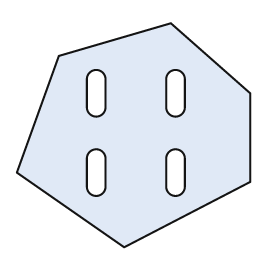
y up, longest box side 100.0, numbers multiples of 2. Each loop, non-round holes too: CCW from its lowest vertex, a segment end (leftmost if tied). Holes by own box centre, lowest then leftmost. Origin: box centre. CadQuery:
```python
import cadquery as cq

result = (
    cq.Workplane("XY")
    .moveTo(-4.0, -48.0)
    .lineTo(50.0, -20.0)
    .lineTo(50.0, 18.0)
    .lineTo(16.0, 48.0)
    .lineTo(-32.0, 34.0)
    .lineTo(-50.0, -16.0)
    .close()
    .moveTo(-20.0, -22.0)
    .threePointArc((-16.0, -26.0), (-12.0, -22.0))
    .lineTo(-12.0, -10.0)
    .threePointArc((-16.0, -6.0), (-20.0, -10.0))
    .close()
    .moveTo(14.0, -22.0)
    .threePointArc((18.0, -26.0), (22.0, -22.0))
    .lineTo(22.0, -10.0)
    .threePointArc((18.0, -6.0), (14.0, -10.0))
    .close()
    .moveTo(-20.0, 12.0)
    .threePointArc((-16.0, 8.0), (-12.0, 12.0))
    .lineTo(-12.0, 24.0)
    .threePointArc((-16.0, 28.0), (-20.0, 24.0))
    .close()
    .moveTo(14.0, 12.0)
    .threePointArc((18.0, 8.0), (22.0, 12.0))
    .lineTo(22.0, 24.0)
    .threePointArc((18.0, 28.0), (14.0, 24.0))
    .close()
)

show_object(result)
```